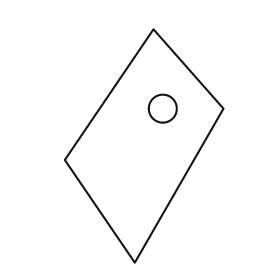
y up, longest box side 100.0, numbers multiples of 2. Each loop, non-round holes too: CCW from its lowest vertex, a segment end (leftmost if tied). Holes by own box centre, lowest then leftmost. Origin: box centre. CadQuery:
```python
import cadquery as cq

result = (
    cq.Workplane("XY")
    .moveTo(-4.0, -50.0)
    .lineTo(34.0, 16.0)
    .lineTo(4.0, 50.0)
    .lineTo(-34.0, -6.0)
    .close()
    .moveTo(8.0, 16.0)
    .circle(6.0)
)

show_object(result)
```